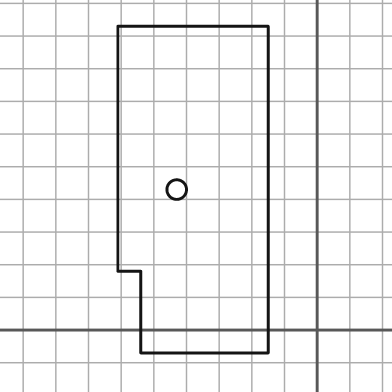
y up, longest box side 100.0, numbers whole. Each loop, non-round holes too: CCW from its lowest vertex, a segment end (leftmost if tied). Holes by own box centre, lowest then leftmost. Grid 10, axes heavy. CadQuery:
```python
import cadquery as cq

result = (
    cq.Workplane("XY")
    .moveTo(-54.0, -7.0)
    .lineTo(-15.0, -7.0)
    .lineTo(-15.0, 93.0)
    .lineTo(-61.0, 93.0)
    .lineTo(-61.0, 18.0)
    .lineTo(-54.0, 18.0)
    .close()
    .moveTo(-43.0, 43.0)
    .circle(3.0)
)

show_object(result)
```